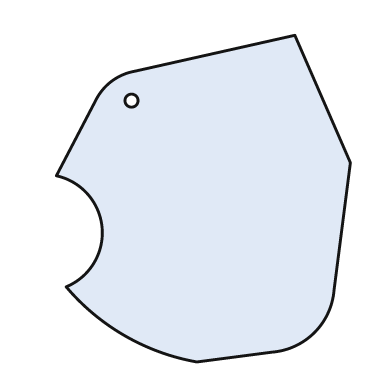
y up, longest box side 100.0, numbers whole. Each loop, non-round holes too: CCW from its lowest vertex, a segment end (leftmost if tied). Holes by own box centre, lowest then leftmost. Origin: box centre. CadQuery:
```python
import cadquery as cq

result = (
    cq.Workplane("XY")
    .moveTo(-2.0, -50.0)
    .lineTo(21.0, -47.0)
    .threePointArc((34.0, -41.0), (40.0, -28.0))
    .lineTo(45.0, 11.0)
    .lineTo(28.0, 50.0)
    .lineTo(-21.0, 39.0)
    .threePointArc((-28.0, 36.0), (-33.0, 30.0))
    .lineTo(-45.0, 7.0)
    .threePointArc((-31.0, -9.0), (-42.0, -27.0))
    .threePointArc((-24.0, -42.0), (-2.0, -50.0))
    .close()
    .moveTo(-22.0, 30.0)
    .circle(2.0)
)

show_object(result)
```